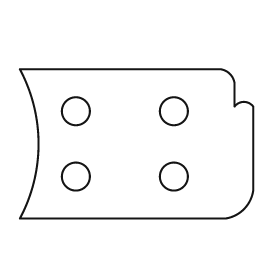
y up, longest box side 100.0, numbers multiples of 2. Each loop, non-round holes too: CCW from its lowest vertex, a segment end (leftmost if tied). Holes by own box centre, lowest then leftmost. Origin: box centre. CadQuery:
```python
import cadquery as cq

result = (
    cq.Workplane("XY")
    .moveTo(-50.0, -32.0)
    .lineTo(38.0, -32.0)
    .threePointArc((46.0, -28.0), (50.0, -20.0))
    .lineTo(50.0, 16.0)
    .threePointArc((46.0, 18.0), (42.0, 16.0))
    .lineTo(42.0, 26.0)
    .threePointArc((40.0, 30.0), (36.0, 32.0))
    .lineTo(-50.0, 32.0)
    .threePointArc((-42.0, 0.0), (-50.0, -32.0))
    .close()
    .moveTo(-26.0, -14.0)
    .circle(6.0)
    .moveTo(16.0, -14.0)
    .circle(6.0)
    .moveTo(-26.0, 14.0)
    .circle(6.0)
    .moveTo(16.0, 14.0)
    .circle(6.0)
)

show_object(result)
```